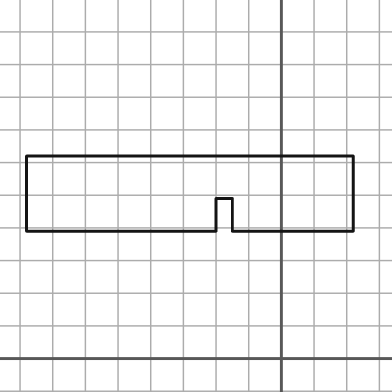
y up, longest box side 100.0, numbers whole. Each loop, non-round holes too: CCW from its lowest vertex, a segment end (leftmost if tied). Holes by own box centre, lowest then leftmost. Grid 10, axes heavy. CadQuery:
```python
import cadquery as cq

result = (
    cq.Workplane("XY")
    .moveTo(-78.0, 39.0)
    .lineTo(-20.0, 39.0)
    .lineTo(-20.0, 49.0)
    .lineTo(-15.0, 49.0)
    .lineTo(-15.0, 39.0)
    .lineTo(22.0, 39.0)
    .lineTo(22.0, 62.0)
    .lineTo(-78.0, 62.0)
    .close()
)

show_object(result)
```